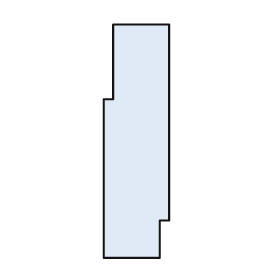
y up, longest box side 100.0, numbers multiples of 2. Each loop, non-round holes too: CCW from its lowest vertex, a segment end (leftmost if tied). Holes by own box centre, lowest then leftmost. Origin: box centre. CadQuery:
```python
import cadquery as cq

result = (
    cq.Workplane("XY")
    .moveTo(-14.0, -50.0)
    .lineTo(10.0, -50.0)
    .lineTo(10.0, -34.0)
    .lineTo(14.0, -34.0)
    .lineTo(14.0, 50.0)
    .lineTo(-10.0, 50.0)
    .lineTo(-10.0, 18.0)
    .lineTo(-14.0, 18.0)
    .close()
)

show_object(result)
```